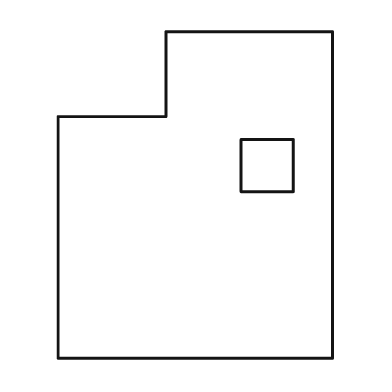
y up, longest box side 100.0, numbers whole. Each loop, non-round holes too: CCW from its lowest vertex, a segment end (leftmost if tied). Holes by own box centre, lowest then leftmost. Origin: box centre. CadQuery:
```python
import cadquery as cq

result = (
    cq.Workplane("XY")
    .moveTo(-42.0, -50.0)
    .lineTo(42.0, -50.0)
    .lineTo(42.0, 50.0)
    .lineTo(-9.0, 50.0)
    .lineTo(-9.0, 24.0)
    .lineTo(-42.0, 24.0)
    .close()
    .moveTo(14.0, 1.0)
    .lineTo(30.0, 1.0)
    .lineTo(30.0, 17.0)
    .lineTo(14.0, 17.0)
    .close()
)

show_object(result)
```